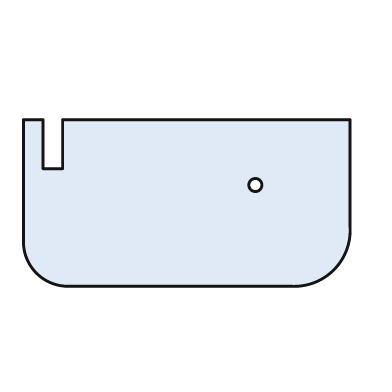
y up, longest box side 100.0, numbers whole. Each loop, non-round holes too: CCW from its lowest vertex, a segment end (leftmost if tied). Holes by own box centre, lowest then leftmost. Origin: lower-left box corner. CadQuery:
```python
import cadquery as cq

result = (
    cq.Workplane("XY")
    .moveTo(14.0, 0.0)
    .lineTo(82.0, 0.0)
    .threePointArc((95.0, 5.0), (100.0, 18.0))
    .lineTo(100.0, 51.0)
    .lineTo(12.0, 51.0)
    .lineTo(12.0, 36.0)
    .lineTo(6.0, 36.0)
    .lineTo(6.0, 51.0)
    .lineTo(0.0, 51.0)
    .lineTo(0.0, 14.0)
    .threePointArc((4.0, 4.0), (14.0, 0.0))
    .close()
    .moveTo(71.0, 31.0)
    .circle(2.0)
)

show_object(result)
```